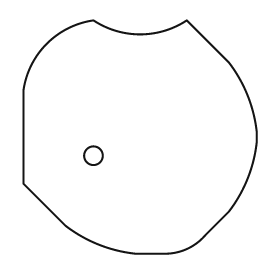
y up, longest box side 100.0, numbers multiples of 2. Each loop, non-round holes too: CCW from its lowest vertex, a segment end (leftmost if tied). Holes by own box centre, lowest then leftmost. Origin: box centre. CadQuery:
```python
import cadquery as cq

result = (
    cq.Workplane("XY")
    .moveTo(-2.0, -50.0)
    .lineTo(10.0, -50.0)
    .threePointArc((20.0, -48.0), (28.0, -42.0))
    .lineTo(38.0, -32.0)
    .threePointArc((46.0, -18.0), (50.0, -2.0))
    .lineTo(50.0, 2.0)
    .threePointArc((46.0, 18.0), (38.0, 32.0))
    .lineTo(20.0, 50.0)
    .threePointArc((0.0, 44.0), (-20.0, 50.0))
    .threePointArc((-40.0, 40.0), (-50.0, 20.0))
    .lineTo(-50.0, -20.0)
    .lineTo(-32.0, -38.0)
    .threePointArc((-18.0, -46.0), (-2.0, -50.0))
    .close()
    .moveTo(-20.0, -8.0)
    .circle(4.0)
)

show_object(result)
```